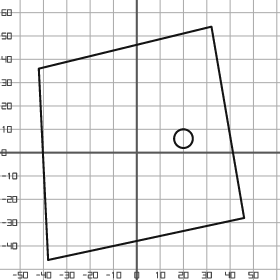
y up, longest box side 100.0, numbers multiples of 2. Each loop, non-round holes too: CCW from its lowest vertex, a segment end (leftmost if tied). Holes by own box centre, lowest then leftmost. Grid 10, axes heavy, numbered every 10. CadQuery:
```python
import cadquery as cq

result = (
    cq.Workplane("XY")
    .moveTo(-38.0, -46.0)
    .lineTo(46.0, -28.0)
    .lineTo(32.0, 54.0)
    .lineTo(-42.0, 36.0)
    .close()
    .moveTo(20.0, 6.0)
    .circle(4.0)
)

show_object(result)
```